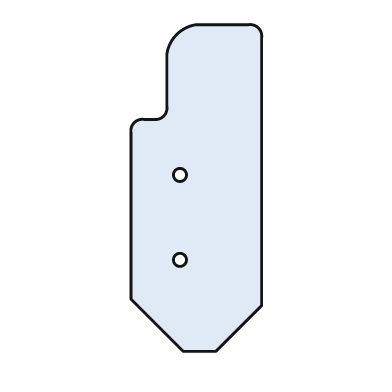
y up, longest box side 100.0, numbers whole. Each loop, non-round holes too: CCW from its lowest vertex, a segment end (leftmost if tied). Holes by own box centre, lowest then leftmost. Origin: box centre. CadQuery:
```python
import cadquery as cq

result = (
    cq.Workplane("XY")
    .moveTo(-4.0, -50.0)
    .lineTo(6.0, -50.0)
    .lineTo(20.0, -36.0)
    .lineTo(20.0, 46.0)
    .threePointArc((19.0, 49.0), (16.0, 50.0))
    .lineTo(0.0, 50.0)
    .threePointArc((-6.0, 47.0), (-9.0, 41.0))
    .lineTo(-9.0, 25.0)
    .threePointArc((-10.0, 22.0), (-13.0, 21.0))
    .lineTo(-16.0, 21.0)
    .threePointArc((-19.0, 20.0), (-20.0, 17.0))
    .lineTo(-20.0, -34.0)
    .close()
    .moveTo(-5.0, -22.0)
    .circle(2.0)
    .moveTo(-5.0, 4.0)
    .circle(2.0)
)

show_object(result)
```